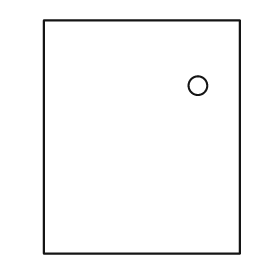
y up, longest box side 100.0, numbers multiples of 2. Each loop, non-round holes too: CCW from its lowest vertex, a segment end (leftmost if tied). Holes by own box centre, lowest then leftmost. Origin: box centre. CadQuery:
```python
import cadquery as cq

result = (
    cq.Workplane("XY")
    .moveTo(-42.0, -50.0)
    .lineTo(42.0, -50.0)
    .lineTo(42.0, 50.0)
    .lineTo(-42.0, 50.0)
    .close()
    .moveTo(24.0, 22.0)
    .circle(4.0)
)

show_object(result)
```